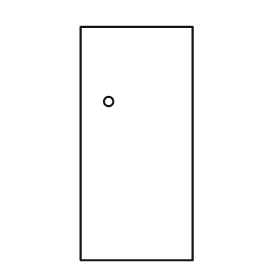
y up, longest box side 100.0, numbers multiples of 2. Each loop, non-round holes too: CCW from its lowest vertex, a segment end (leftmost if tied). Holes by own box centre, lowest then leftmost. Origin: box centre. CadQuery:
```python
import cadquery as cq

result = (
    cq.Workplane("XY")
    .moveTo(-24.0, -50.0)
    .lineTo(24.0, -50.0)
    .lineTo(24.0, 50.0)
    .lineTo(-24.0, 50.0)
    .close()
    .moveTo(-12.0, 18.0)
    .circle(2.0)
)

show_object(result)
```